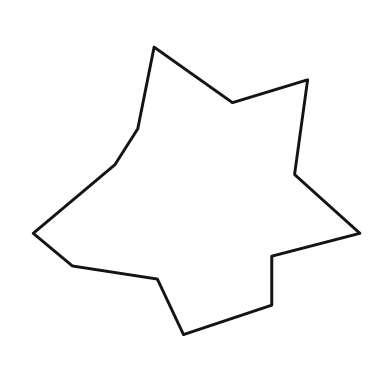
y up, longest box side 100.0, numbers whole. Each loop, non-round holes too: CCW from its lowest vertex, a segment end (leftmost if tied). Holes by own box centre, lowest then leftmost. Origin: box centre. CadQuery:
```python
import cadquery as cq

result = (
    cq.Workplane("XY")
    .moveTo(-4.0, -44.0)
    .lineTo(23.0, -35.0)
    .lineTo(23.0, -20.0)
    .lineTo(50.0, -13.0)
    .lineTo(30.0, 5.0)
    .lineTo(34.0, 34.0)
    .lineTo(11.0, 27.0)
    .lineTo(-13.0, 44.0)
    .lineTo(-18.0, 19.0)
    .lineTo(-25.0, 8.0)
    .lineTo(-50.0, -13.0)
    .lineTo(-38.0, -23.0)
    .lineTo(-12.0, -27.0)
    .close()
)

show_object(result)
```